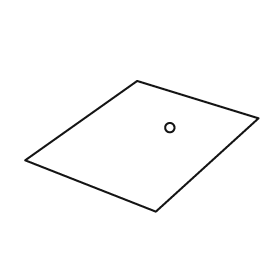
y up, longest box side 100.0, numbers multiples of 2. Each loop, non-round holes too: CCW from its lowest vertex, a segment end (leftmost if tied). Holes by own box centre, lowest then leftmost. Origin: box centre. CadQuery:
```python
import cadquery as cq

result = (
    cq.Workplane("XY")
    .moveTo(6.0, -28.0)
    .lineTo(50.0, 12.0)
    .lineTo(-2.0, 28.0)
    .lineTo(-50.0, -6.0)
    .close()
    .moveTo(12.0, 8.0)
    .circle(2.0)
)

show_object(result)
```